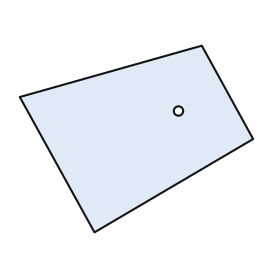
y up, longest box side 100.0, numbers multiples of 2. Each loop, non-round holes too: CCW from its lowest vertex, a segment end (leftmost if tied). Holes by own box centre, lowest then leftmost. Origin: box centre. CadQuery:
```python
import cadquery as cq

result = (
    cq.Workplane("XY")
    .moveTo(-18.0, -40.0)
    .lineTo(50.0, 0.0)
    .lineTo(28.0, 40.0)
    .lineTo(-50.0, 18.0)
    .close()
    .moveTo(18.0, 12.0)
    .circle(2.0)
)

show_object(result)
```